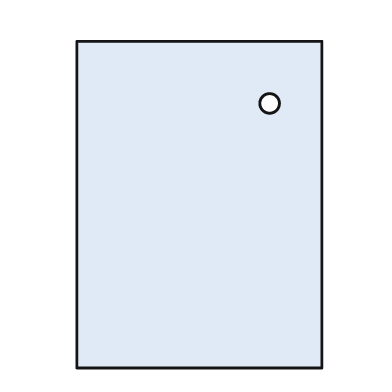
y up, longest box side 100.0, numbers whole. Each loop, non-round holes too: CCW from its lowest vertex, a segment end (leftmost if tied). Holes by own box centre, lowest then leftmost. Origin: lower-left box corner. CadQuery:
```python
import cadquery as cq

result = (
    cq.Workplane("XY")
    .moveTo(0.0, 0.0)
    .lineTo(75.0, 0.0)
    .lineTo(75.0, 100.0)
    .lineTo(0.0, 100.0)
    .close()
    .moveTo(59.0, 81.0)
    .circle(3.0)
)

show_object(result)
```